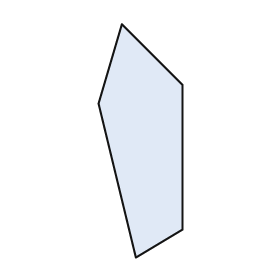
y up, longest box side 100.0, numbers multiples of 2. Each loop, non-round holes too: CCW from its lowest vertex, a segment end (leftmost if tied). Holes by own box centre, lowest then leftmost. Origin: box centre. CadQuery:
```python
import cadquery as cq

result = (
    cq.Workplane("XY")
    .moveTo(-2.0, -50.0)
    .lineTo(18.0, -38.0)
    .lineTo(18.0, 24.0)
    .lineTo(-8.0, 50.0)
    .lineTo(-18.0, 16.0)
    .close()
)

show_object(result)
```